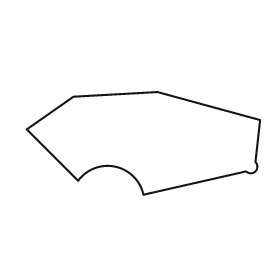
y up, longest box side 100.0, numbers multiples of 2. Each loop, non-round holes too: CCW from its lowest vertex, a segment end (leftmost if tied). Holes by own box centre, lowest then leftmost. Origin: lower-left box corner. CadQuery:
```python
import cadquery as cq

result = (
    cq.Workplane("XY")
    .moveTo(50.0, 0.0)
    .lineTo(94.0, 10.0)
    .threePointArc((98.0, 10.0), (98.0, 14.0))
    .lineTo(100.0, 32.0)
    .lineTo(56.0, 44.0)
    .lineTo(20.0, 42.0)
    .lineTo(0.0, 28.0)
    .lineTo(22.0, 6.0)
    .threePointArc((38.0, 12.0), (50.0, 0.0))
    .close()
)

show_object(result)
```